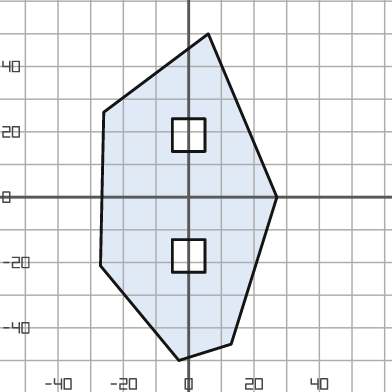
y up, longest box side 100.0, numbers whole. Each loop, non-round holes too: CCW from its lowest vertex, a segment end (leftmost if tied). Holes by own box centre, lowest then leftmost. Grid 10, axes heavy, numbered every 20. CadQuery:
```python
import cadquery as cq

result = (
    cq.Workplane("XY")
    .moveTo(-3.0, -50.0)
    .lineTo(13.0, -45.0)
    .lineTo(27.0, 0.0)
    .lineTo(6.0, 50.0)
    .lineTo(-26.0, 26.0)
    .lineTo(-27.0, -21.0)
    .close()
    .moveTo(-5.0, -23.0)
    .lineTo(5.0, -23.0)
    .lineTo(5.0, -13.0)
    .lineTo(-5.0, -13.0)
    .close()
    .moveTo(-5.0, 14.0)
    .lineTo(5.0, 14.0)
    .lineTo(5.0, 24.0)
    .lineTo(-5.0, 24.0)
    .close()
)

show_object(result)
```